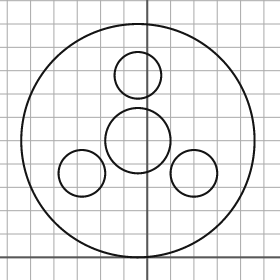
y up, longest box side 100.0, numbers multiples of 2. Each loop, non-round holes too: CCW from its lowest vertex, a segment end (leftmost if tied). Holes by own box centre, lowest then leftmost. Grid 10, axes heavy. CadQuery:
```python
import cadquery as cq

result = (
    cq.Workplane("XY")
    .moveTo(-4.0, 50.0)
    .circle(50.0)
    .moveTo(-28.0, 36.0)
    .circle(10.0)
    .moveTo(20.0, 36.0)
    .circle(10.0)
    .moveTo(-4.0, 50.0)
    .circle(14.0)
    .moveTo(-4.0, 78.0)
    .circle(10.0)
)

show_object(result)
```